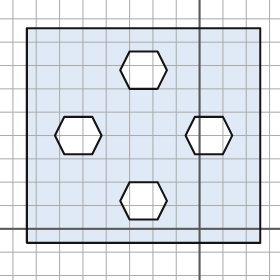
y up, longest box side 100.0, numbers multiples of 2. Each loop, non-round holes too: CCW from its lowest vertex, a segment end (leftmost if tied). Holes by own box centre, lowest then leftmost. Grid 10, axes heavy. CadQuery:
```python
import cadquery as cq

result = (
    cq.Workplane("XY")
    .moveTo(-74.0, -6.0)
    .lineTo(26.0, -6.0)
    .lineTo(26.0, 86.0)
    .lineTo(-74.0, 86.0)
    .close()
    .moveTo(-30.0, 4.0)
    .lineTo(-18.0, 4.0)
    .lineTo(-14.0, 12.0)
    .lineTo(-18.0, 20.0)
    .lineTo(-30.0, 20.0)
    .lineTo(-34.0, 12.0)
    .close()
    .moveTo(-58.0, 32.0)
    .lineTo(-46.0, 32.0)
    .lineTo(-42.0, 40.0)
    .lineTo(-46.0, 48.0)
    .lineTo(-58.0, 48.0)
    .lineTo(-62.0, 40.0)
    .close()
    .moveTo(-2.0, 32.0)
    .lineTo(10.0, 32.0)
    .lineTo(14.0, 40.0)
    .lineTo(10.0, 48.0)
    .lineTo(-2.0, 48.0)
    .lineTo(-6.0, 40.0)
    .close()
    .moveTo(-30.0, 60.0)
    .lineTo(-18.0, 60.0)
    .lineTo(-14.0, 68.0)
    .lineTo(-18.0, 76.0)
    .lineTo(-30.0, 76.0)
    .lineTo(-34.0, 68.0)
    .close()
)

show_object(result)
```